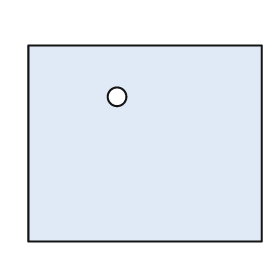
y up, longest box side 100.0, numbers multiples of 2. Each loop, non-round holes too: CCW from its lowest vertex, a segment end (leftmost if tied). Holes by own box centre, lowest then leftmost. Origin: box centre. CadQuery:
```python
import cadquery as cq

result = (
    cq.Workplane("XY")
    .moveTo(-50.0, -42.0)
    .lineTo(50.0, -42.0)
    .lineTo(50.0, 42.0)
    .lineTo(-50.0, 42.0)
    .close()
    .moveTo(-12.0, 20.0)
    .circle(4.0)
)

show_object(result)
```